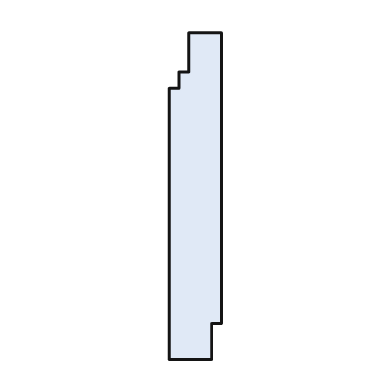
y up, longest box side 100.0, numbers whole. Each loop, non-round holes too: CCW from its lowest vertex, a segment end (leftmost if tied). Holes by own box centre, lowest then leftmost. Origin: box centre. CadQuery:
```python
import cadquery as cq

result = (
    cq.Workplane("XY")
    .moveTo(-8.0, -50.0)
    .lineTo(5.0, -50.0)
    .lineTo(5.0, -39.0)
    .lineTo(8.0, -39.0)
    .lineTo(8.0, 50.0)
    .lineTo(-2.0, 50.0)
    .lineTo(-2.0, 38.0)
    .lineTo(-5.0, 38.0)
    .lineTo(-5.0, 33.0)
    .lineTo(-8.0, 33.0)
    .close()
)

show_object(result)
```